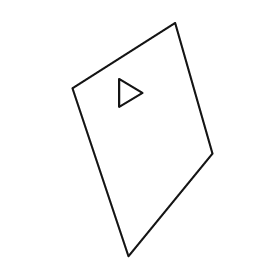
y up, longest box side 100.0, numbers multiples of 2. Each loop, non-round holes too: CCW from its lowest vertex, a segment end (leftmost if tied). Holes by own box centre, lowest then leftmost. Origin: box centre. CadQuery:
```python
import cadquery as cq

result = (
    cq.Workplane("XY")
    .moveTo(-6.0, -50.0)
    .lineTo(30.0, -6.0)
    .lineTo(14.0, 50.0)
    .lineTo(-30.0, 22.0)
    .close()
    .moveTo(-10.0, 14.0)
    .lineTo(0.0, 20.0)
    .lineTo(-10.0, 26.0)
    .close()
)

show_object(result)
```